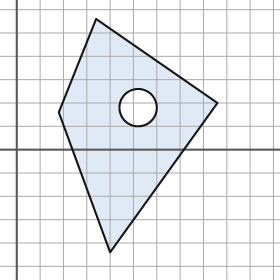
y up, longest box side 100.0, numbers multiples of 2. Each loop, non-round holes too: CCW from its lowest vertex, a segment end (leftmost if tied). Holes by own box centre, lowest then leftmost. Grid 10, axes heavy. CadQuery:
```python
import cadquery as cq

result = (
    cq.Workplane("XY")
    .moveTo(40.0, -44.0)
    .lineTo(86.0, 20.0)
    .lineTo(34.0, 56.0)
    .lineTo(18.0, 16.0)
    .close()
    .moveTo(52.0, 18.0)
    .circle(8.0)
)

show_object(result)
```